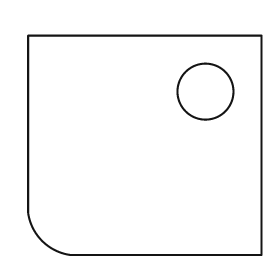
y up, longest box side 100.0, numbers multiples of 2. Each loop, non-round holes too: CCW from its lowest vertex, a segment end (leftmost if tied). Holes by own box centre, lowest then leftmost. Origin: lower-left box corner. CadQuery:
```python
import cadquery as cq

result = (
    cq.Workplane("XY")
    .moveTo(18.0, 0.0)
    .lineTo(100.0, 0.0)
    .lineTo(100.0, 94.0)
    .lineTo(0.0, 94.0)
    .lineTo(0.0, 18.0)
    .threePointArc((6.0, 6.0), (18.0, 0.0))
    .close()
    .moveTo(76.0, 70.0)
    .circle(12.0)
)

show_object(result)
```